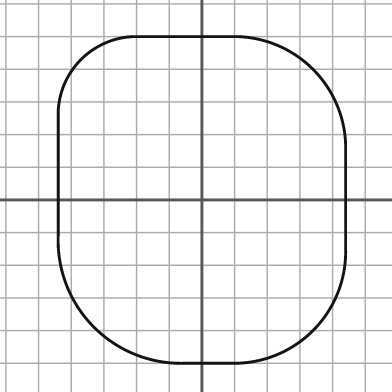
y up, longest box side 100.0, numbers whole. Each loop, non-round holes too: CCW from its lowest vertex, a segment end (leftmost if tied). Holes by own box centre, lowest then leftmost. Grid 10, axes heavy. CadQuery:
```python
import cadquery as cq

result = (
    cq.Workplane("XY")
    .moveTo(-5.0, -50.0)
    .lineTo(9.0, -50.0)
    .threePointArc((34.0, -40.0), (44.0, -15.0))
    .lineTo(44.0, 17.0)
    .threePointArc((34.0, 40.0), (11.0, 50.0))
    .lineTo(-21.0, 50.0)
    .threePointArc((-37.0, 43.0), (-44.0, 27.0))
    .lineTo(-44.0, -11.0)
    .threePointArc((-33.0, -39.0), (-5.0, -50.0))
    .close()
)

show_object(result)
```